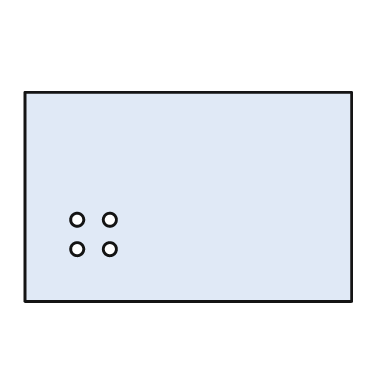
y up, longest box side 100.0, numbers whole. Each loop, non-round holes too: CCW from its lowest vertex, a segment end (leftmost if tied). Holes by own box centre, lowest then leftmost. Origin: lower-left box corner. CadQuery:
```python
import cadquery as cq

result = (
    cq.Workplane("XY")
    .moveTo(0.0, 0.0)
    .lineTo(100.0, 0.0)
    .lineTo(100.0, 64.0)
    .lineTo(0.0, 64.0)
    .close()
    .moveTo(16.0, 16.0)
    .circle(2.0)
    .moveTo(26.0, 16.0)
    .circle(2.0)
    .moveTo(16.0, 25.0)
    .circle(2.0)
    .moveTo(26.0, 25.0)
    .circle(2.0)
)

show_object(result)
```